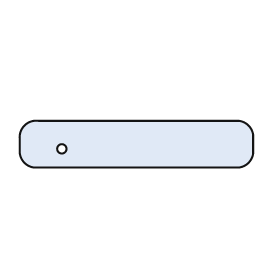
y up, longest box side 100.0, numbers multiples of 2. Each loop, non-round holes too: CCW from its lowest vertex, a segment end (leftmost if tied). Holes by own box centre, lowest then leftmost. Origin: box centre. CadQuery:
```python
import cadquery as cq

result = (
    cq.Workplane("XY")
    .moveTo(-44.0, -10.0)
    .lineTo(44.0, -10.0)
    .threePointArc((48.0, -8.0), (50.0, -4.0))
    .lineTo(50.0, 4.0)
    .threePointArc((48.0, 8.0), (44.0, 10.0))
    .lineTo(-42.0, 10.0)
    .threePointArc((-48.0, 8.0), (-50.0, 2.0))
    .lineTo(-50.0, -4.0)
    .threePointArc((-48.0, -8.0), (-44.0, -10.0))
    .close()
    .moveTo(-32.0, -2.0)
    .circle(2.0)
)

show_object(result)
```